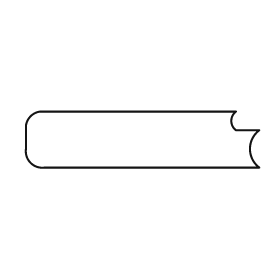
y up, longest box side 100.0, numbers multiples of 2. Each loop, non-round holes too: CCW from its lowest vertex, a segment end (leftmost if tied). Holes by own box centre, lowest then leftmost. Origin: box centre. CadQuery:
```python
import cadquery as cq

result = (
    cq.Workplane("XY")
    .moveTo(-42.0, -12.0)
    .lineTo(50.0, -12.0)
    .threePointArc((46.0, -4.0), (50.0, 4.0))
    .lineTo(40.0, 4.0)
    .threePointArc((38.0, 8.0), (40.0, 12.0))
    .lineTo(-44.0, 12.0)
    .threePointArc((-48.0, 10.0), (-50.0, 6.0))
    .lineTo(-50.0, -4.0)
    .threePointArc((-48.0, -10.0), (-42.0, -12.0))
    .close()
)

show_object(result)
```